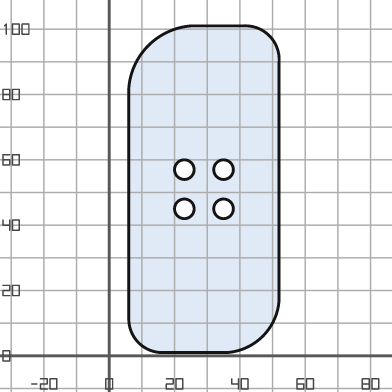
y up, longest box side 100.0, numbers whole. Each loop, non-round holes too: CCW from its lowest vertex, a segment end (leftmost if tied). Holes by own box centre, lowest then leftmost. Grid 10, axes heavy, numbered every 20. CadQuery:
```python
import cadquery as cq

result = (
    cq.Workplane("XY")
    .moveTo(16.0, 1.0)
    .lineTo(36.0, 1.0)
    .threePointArc((47.0, 6.0), (52.0, 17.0))
    .lineTo(52.0, 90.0)
    .threePointArc((49.0, 98.0), (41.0, 101.0))
    .lineTo(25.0, 101.0)
    .threePointArc((12.0, 95.0), (6.0, 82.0))
    .lineTo(6.0, 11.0)
    .threePointArc((9.0, 4.0), (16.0, 1.0))
    .close()
    .moveTo(23.0, 45.0)
    .circle(3.0)
    .moveTo(35.0, 45.0)
    .circle(3.0)
    .moveTo(23.0, 57.0)
    .circle(3.0)
    .moveTo(35.0, 57.0)
    .circle(3.0)
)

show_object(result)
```